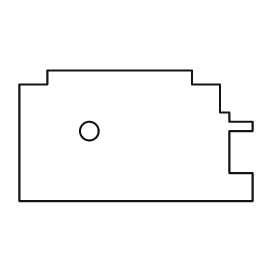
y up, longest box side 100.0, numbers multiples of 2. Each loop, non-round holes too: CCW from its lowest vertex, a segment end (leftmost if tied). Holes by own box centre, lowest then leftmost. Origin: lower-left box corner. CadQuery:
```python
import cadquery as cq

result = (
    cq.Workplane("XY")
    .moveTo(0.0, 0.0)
    .lineTo(100.0, 0.0)
    .lineTo(100.0, 12.0)
    .lineTo(90.0, 12.0)
    .lineTo(90.0, 30.0)
    .lineTo(100.0, 30.0)
    .lineTo(100.0, 34.0)
    .lineTo(90.0, 34.0)
    .lineTo(90.0, 38.0)
    .lineTo(86.0, 38.0)
    .lineTo(86.0, 50.0)
    .lineTo(74.0, 50.0)
    .lineTo(74.0, 56.0)
    .lineTo(12.0, 56.0)
    .lineTo(12.0, 50.0)
    .lineTo(0.0, 50.0)
    .close()
    .moveTo(30.0, 30.0)
    .circle(4.0)
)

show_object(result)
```